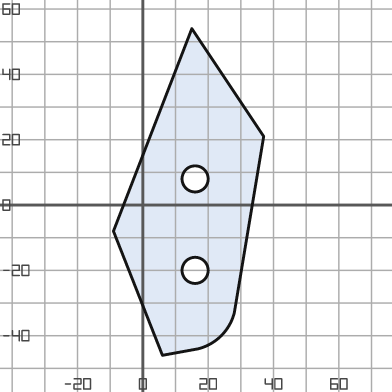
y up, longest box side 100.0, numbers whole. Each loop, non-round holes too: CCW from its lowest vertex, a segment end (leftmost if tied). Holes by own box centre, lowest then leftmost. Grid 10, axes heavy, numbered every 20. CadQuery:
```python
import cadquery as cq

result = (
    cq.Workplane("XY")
    .moveTo(6.0, -46.0)
    .lineTo(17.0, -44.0)
    .threePointArc((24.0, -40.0), (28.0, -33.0))
    .lineTo(37.0, 21.0)
    .lineTo(15.0, 54.0)
    .lineTo(-9.0, -8.0)
    .close()
    .moveTo(16.0, -20.0)
    .circle(4.0)
    .moveTo(16.0, 8.0)
    .circle(4.0)
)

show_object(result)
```